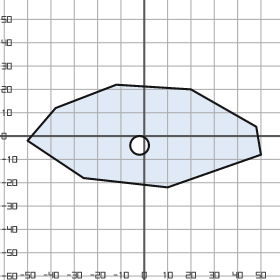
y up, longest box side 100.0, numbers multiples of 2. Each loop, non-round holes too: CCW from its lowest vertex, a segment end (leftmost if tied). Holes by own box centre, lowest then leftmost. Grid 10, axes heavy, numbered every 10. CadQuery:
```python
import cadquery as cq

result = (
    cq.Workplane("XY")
    .moveTo(10.0, -22.0)
    .lineTo(50.0, -8.0)
    .lineTo(48.0, 4.0)
    .lineTo(20.0, 20.0)
    .lineTo(-12.0, 22.0)
    .lineTo(-38.0, 12.0)
    .lineTo(-50.0, -2.0)
    .lineTo(-26.0, -18.0)
    .close()
    .moveTo(-2.0, -4.0)
    .circle(4.0)
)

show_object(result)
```